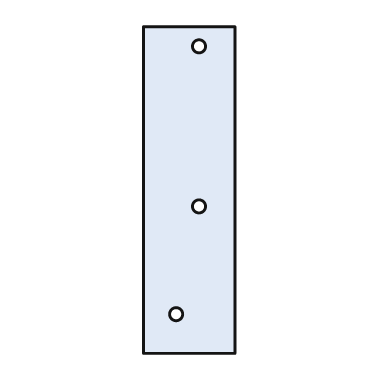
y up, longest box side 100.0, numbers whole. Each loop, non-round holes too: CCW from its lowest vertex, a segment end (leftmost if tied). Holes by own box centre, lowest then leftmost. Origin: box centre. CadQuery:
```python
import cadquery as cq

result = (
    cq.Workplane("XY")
    .moveTo(-14.0, -50.0)
    .lineTo(14.0, -50.0)
    .lineTo(14.0, 50.0)
    .lineTo(-14.0, 50.0)
    .close()
    .moveTo(-4.0, -38.0)
    .circle(2.0)
    .moveTo(3.0, -5.0)
    .circle(2.0)
    .moveTo(3.0, 44.0)
    .circle(2.0)
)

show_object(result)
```